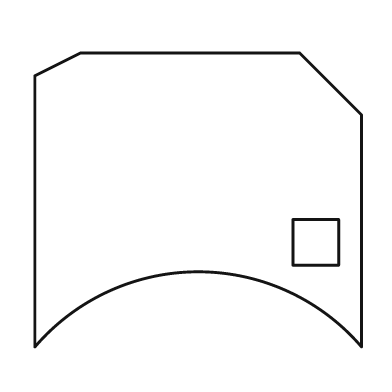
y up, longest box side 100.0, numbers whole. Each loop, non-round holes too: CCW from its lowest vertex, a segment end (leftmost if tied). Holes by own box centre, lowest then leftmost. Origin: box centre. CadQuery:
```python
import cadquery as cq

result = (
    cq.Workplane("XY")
    .moveTo(-50.0, -45.0)
    .threePointArc((0.0, -22.0), (50.0, -45.0))
    .lineTo(50.0, 26.0)
    .lineTo(31.0, 45.0)
    .lineTo(-36.0, 45.0)
    .lineTo(-50.0, 38.0)
    .close()
    .moveTo(29.0, -20.0)
    .lineTo(43.0, -20.0)
    .lineTo(43.0, -6.0)
    .lineTo(29.0, -6.0)
    .close()
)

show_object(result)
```